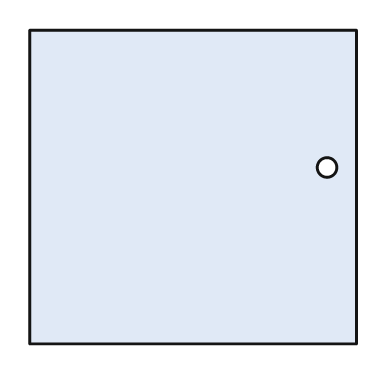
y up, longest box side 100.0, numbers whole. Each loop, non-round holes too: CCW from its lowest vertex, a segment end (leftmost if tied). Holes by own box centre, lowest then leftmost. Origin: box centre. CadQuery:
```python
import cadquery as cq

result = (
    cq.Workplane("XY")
    .moveTo(-50.0, -48.0)
    .lineTo(50.0, -48.0)
    .lineTo(50.0, 48.0)
    .lineTo(-50.0, 48.0)
    .close()
    .moveTo(41.0, 6.0)
    .circle(3.0)
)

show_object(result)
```